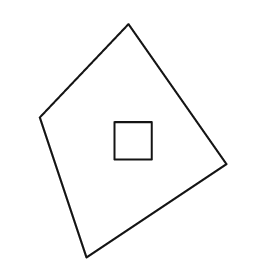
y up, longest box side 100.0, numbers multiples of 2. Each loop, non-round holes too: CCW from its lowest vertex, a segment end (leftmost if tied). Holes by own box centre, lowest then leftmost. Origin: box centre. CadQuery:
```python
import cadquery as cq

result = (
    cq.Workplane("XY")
    .moveTo(-20.0, -50.0)
    .lineTo(40.0, -10.0)
    .lineTo(-2.0, 50.0)
    .lineTo(-40.0, 10.0)
    .close()
    .moveTo(-8.0, -8.0)
    .lineTo(8.0, -8.0)
    .lineTo(8.0, 8.0)
    .lineTo(-8.0, 8.0)
    .close()
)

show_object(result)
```